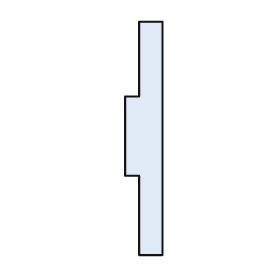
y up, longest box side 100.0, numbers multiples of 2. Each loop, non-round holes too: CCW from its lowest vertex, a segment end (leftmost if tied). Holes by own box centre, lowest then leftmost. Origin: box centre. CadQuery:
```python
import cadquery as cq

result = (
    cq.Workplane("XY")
    .moveTo(-2.0, -50.0)
    .lineTo(8.0, -50.0)
    .lineTo(8.0, 50.0)
    .lineTo(-2.0, 50.0)
    .lineTo(-2.0, 18.0)
    .lineTo(-8.0, 18.0)
    .lineTo(-8.0, -16.0)
    .lineTo(-2.0, -16.0)
    .close()
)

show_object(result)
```